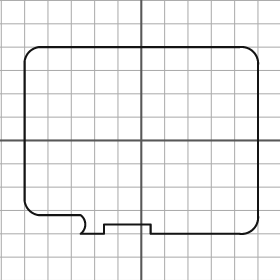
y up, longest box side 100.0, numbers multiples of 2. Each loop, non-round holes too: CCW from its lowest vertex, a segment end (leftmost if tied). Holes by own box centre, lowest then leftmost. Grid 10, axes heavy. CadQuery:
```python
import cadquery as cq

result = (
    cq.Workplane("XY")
    .moveTo(-26.0, -40.0)
    .lineTo(-16.0, -40.0)
    .lineTo(-16.0, -36.0)
    .lineTo(4.0, -36.0)
    .lineTo(4.0, -40.0)
    .lineTo(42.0, -40.0)
    .threePointArc((48.0, -38.0), (50.0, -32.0))
    .lineTo(50.0, 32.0)
    .threePointArc((48.0, 38.0), (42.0, 40.0))
    .lineTo(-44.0, 40.0)
    .threePointArc((-48.0, 38.0), (-50.0, 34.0))
    .lineTo(-50.0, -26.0)
    .threePointArc((-48.0, -30.0), (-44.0, -32.0))
    .lineTo(-26.0, -32.0)
    .threePointArc((-24.0, -36.0), (-26.0, -40.0))
    .close()
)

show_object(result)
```